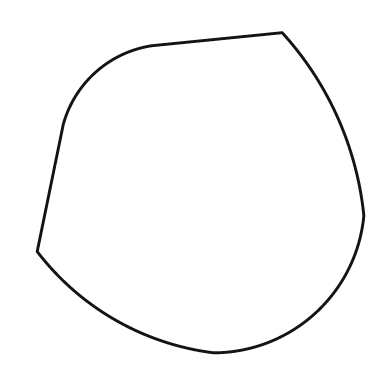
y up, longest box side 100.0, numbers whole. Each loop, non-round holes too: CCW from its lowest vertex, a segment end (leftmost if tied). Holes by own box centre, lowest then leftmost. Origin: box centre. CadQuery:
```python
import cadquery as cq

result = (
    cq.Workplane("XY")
    .moveTo(4.0, -49.0)
    .threePointArc((35.0, -37.0), (50.0, -7.0))
    .threePointArc((42.0, 23.0), (25.0, 49.0))
    .lineTo(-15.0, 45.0)
    .threePointArc((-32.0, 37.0), (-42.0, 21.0))
    .lineTo(-50.0, -18.0)
    .threePointArc((-26.0, -39.0), (4.0, -49.0))
    .close()
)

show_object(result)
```